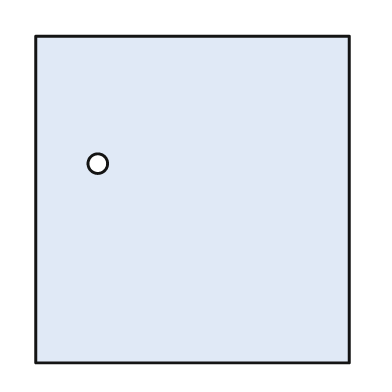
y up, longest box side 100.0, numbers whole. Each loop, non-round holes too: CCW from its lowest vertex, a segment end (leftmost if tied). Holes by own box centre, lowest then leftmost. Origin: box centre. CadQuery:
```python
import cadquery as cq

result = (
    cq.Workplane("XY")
    .moveTo(-48.0, -50.0)
    .lineTo(48.0, -50.0)
    .lineTo(48.0, 50.0)
    .lineTo(-48.0, 50.0)
    .close()
    .moveTo(-29.0, 11.0)
    .circle(3.0)
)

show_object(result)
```